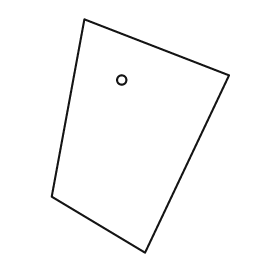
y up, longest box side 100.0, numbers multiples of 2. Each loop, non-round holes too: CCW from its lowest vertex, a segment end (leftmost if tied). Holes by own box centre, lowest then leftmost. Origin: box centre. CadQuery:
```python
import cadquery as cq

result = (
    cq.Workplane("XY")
    .moveTo(2.0, -50.0)
    .lineTo(38.0, 26.0)
    .lineTo(-24.0, 50.0)
    .lineTo(-38.0, -26.0)
    .close()
    .moveTo(-8.0, 24.0)
    .circle(2.0)
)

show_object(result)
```